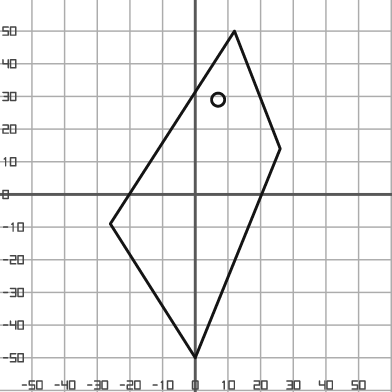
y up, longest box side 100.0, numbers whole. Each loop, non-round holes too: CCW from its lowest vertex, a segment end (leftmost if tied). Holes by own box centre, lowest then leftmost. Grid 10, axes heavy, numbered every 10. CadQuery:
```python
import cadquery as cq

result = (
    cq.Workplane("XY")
    .moveTo(0.0, -50.0)
    .lineTo(26.0, 14.0)
    .lineTo(12.0, 50.0)
    .lineTo(-26.0, -9.0)
    .close()
    .moveTo(7.0, 29.0)
    .circle(2.0)
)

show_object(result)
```